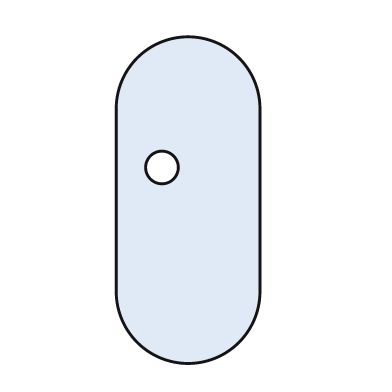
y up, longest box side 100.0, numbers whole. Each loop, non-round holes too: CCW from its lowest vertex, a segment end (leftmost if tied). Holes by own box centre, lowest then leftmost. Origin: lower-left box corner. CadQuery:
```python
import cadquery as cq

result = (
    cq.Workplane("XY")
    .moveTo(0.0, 22.0)
    .threePointArc((22.0, 0.0), (44.0, 22.0))
    .lineTo(44.0, 78.0)
    .threePointArc((22.0, 100.0), (0.0, 78.0))
    .close()
    .moveTo(14.0, 60.0)
    .circle(5.0)
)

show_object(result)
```